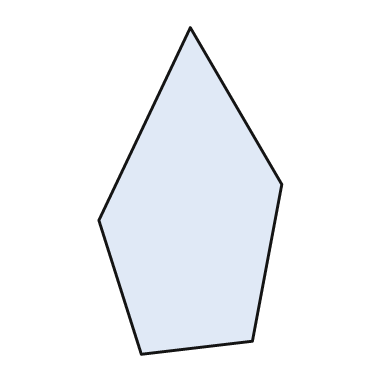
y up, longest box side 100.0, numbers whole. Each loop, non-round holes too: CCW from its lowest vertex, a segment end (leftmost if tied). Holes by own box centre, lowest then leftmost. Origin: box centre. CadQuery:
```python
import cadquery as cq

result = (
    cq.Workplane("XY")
    .moveTo(-15.0, -50.0)
    .lineTo(19.0, -46.0)
    .lineTo(28.0, 2.0)
    .lineTo(0.0, 50.0)
    .lineTo(-28.0, -9.0)
    .close()
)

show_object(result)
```